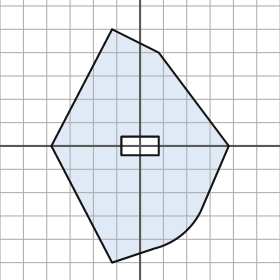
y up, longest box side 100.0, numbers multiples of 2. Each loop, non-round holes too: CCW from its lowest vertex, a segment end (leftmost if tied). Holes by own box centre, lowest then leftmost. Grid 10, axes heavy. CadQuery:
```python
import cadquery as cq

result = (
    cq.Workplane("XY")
    .moveTo(-12.0, -50.0)
    .lineTo(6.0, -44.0)
    .threePointArc((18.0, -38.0), (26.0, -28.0))
    .lineTo(38.0, 0.0)
    .lineTo(8.0, 40.0)
    .lineTo(-12.0, 50.0)
    .lineTo(-38.0, 0.0)
    .close()
    .moveTo(-8.0, -4.0)
    .lineTo(8.0, -4.0)
    .lineTo(8.0, 4.0)
    .lineTo(-8.0, 4.0)
    .close()
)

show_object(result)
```